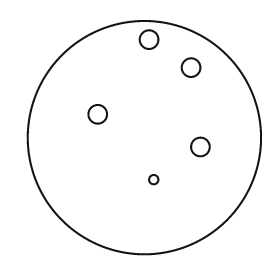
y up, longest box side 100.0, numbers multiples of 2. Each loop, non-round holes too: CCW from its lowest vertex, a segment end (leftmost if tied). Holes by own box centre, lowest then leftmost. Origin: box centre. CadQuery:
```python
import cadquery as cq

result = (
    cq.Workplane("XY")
    .moveTo(0.0, 0.0)
    .circle(50.0)
    .moveTo(4.0, -18.0)
    .circle(2.0)
    .moveTo(24.0, -4.0)
    .circle(4.0)
    .moveTo(-20.0, 10.0)
    .circle(4.0)
    .moveTo(20.0, 30.0)
    .circle(4.0)
    .moveTo(2.0, 42.0)
    .circle(4.0)
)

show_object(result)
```